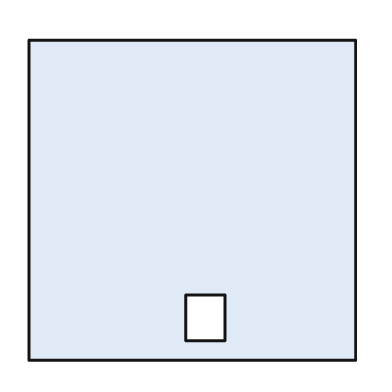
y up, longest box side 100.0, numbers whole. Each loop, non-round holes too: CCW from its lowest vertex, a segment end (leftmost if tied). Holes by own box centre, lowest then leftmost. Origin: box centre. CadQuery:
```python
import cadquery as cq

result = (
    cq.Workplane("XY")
    .moveTo(-50.0, -49.0)
    .lineTo(50.0, -49.0)
    .lineTo(50.0, 49.0)
    .lineTo(-50.0, 49.0)
    .close()
    .moveTo(-2.0, -43.0)
    .lineTo(10.0, -43.0)
    .lineTo(10.0, -29.0)
    .lineTo(-2.0, -29.0)
    .close()
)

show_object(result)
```